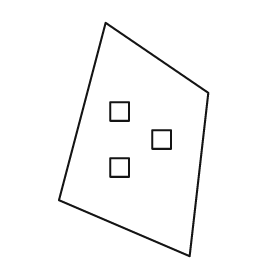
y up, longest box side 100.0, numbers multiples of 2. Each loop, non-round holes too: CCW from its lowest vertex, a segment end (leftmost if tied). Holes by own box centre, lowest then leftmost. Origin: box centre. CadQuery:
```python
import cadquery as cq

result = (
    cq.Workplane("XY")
    .moveTo(24.0, -50.0)
    .lineTo(32.0, 20.0)
    .lineTo(-12.0, 50.0)
    .lineTo(-32.0, -26.0)
    .close()
    .moveTo(-10.0, -16.0)
    .lineTo(-2.0, -16.0)
    .lineTo(-2.0, -8.0)
    .lineTo(-10.0, -8.0)
    .close()
    .moveTo(8.0, -4.0)
    .lineTo(16.0, -4.0)
    .lineTo(16.0, 4.0)
    .lineTo(8.0, 4.0)
    .close()
    .moveTo(-10.0, 8.0)
    .lineTo(-2.0, 8.0)
    .lineTo(-2.0, 16.0)
    .lineTo(-10.0, 16.0)
    .close()
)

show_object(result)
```